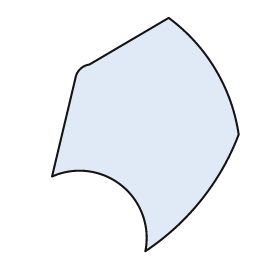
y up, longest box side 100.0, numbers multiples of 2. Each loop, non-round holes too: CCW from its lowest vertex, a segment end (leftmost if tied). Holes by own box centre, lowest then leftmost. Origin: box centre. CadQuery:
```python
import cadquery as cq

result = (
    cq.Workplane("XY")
    .moveTo(0.0, -50.0)
    .threePointArc((24.0, -28.0), (40.0, 0.0))
    .threePointArc((30.0, 28.0), (10.0, 50.0))
    .lineTo(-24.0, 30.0)
    .threePointArc((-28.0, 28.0), (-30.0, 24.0))
    .lineTo(-40.0, -18.0)
    .threePointArc((-10.0, -22.0), (0.0, -50.0))
    .close()
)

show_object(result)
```